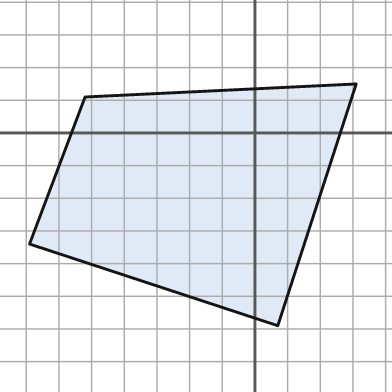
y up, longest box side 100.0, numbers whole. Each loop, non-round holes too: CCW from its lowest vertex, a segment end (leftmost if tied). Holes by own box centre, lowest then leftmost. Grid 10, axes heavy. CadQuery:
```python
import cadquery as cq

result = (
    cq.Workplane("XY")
    .moveTo(7.0, -59.0)
    .lineTo(31.0, 15.0)
    .lineTo(-52.0, 11.0)
    .lineTo(-69.0, -34.0)
    .close()
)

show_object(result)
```